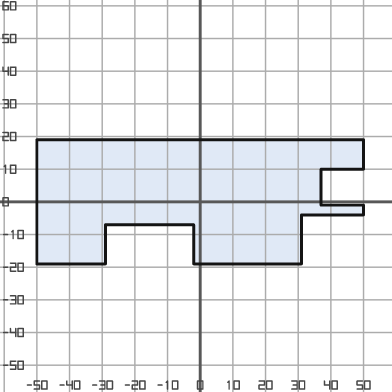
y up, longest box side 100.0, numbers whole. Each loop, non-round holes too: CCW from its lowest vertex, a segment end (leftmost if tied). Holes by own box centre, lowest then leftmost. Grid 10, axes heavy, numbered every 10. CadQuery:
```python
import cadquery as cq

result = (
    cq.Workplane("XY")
    .moveTo(-50.0, -19.0)
    .lineTo(-29.0, -19.0)
    .lineTo(-29.0, -7.0)
    .lineTo(-2.0, -7.0)
    .lineTo(-2.0, -19.0)
    .lineTo(31.0, -19.0)
    .lineTo(31.0, -4.0)
    .lineTo(50.0, -4.0)
    .lineTo(50.0, -1.0)
    .lineTo(37.0, -1.0)
    .lineTo(37.0, 10.0)
    .lineTo(50.0, 10.0)
    .lineTo(50.0, 19.0)
    .lineTo(-50.0, 19.0)
    .close()
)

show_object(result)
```